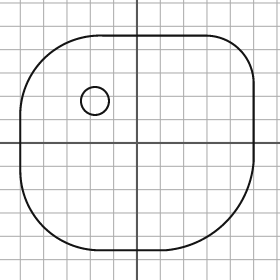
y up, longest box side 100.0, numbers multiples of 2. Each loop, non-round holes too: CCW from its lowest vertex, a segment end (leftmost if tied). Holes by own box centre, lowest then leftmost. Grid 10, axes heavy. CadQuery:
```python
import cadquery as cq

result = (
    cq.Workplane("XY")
    .moveTo(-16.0, -46.0)
    .lineTo(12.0, -46.0)
    .threePointArc((38.0, -34.0), (50.0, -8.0))
    .lineTo(50.0, 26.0)
    .threePointArc((44.0, 40.0), (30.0, 46.0))
    .lineTo(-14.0, 46.0)
    .threePointArc((-40.0, 36.0), (-50.0, 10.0))
    .lineTo(-50.0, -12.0)
    .threePointArc((-40.0, -36.0), (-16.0, -46.0))
    .close()
    .moveTo(-18.0, 18.0)
    .circle(6.0)
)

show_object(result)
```